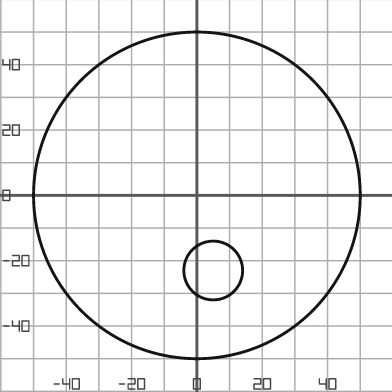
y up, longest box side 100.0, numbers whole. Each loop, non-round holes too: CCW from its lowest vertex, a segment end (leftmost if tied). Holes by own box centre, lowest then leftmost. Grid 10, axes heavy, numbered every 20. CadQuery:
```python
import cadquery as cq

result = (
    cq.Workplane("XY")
    .moveTo(0.0, 0.0)
    .circle(50.0)
    .moveTo(5.0, -23.0)
    .circle(9.0)
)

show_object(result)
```